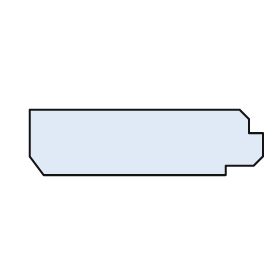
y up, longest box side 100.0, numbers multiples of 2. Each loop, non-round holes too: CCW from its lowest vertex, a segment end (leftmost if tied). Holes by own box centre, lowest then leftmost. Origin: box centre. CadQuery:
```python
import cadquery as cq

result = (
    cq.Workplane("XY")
    .moveTo(-44.0, -14.0)
    .lineTo(34.0, -14.0)
    .lineTo(34.0, -10.0)
    .lineTo(46.0, -10.0)
    .lineTo(50.0, -6.0)
    .lineTo(50.0, 4.0)
    .lineTo(44.0, 4.0)
    .lineTo(44.0, 10.0)
    .lineTo(40.0, 14.0)
    .lineTo(-50.0, 14.0)
    .lineTo(-50.0, -6.0)
    .close()
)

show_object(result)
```